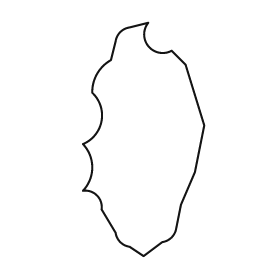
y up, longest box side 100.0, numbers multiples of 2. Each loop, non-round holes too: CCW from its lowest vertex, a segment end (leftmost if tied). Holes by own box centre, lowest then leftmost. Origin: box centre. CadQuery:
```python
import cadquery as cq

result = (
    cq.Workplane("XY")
    .moveTo(0.0, -50.0)
    .lineTo(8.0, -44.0)
    .threePointArc((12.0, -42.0), (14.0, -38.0))
    .lineTo(16.0, -28.0)
    .lineTo(22.0, -14.0)
    .lineTo(26.0, 6.0)
    .lineTo(18.0, 32.0)
    .lineTo(12.0, 38.0)
    .threePointArc((2.0, 40.0), (2.0, 50.0))
    .lineTo(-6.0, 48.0)
    .threePointArc((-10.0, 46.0), (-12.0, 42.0))
    .lineTo(-14.0, 34.0)
    .threePointArc((-20.0, 28.0), (-22.0, 20.0))
    .threePointArc((-18.0, 8.0), (-26.0, -2.0))
    .threePointArc((-22.0, -12.0), (-26.0, -22.0))
    .threePointArc((-20.0, -24.0), (-18.0, -30.0))
    .lineTo(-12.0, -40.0)
    .threePointArc((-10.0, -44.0), (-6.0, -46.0))
    .close()
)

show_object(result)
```